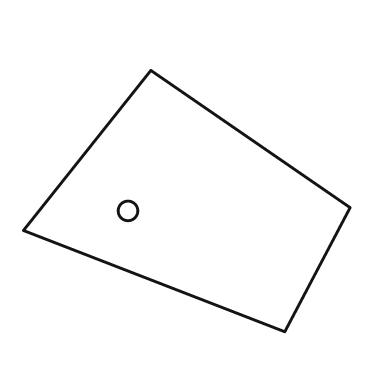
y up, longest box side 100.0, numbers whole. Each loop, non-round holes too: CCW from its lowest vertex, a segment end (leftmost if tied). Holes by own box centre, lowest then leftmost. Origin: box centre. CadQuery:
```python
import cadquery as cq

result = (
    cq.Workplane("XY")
    .moveTo(30.0, -40.0)
    .lineTo(50.0, -2.0)
    .lineTo(-11.0, 40.0)
    .lineTo(-50.0, -9.0)
    .close()
    .moveTo(-18.0, -3.0)
    .circle(3.0)
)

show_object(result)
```